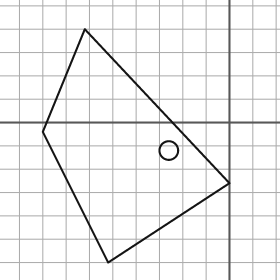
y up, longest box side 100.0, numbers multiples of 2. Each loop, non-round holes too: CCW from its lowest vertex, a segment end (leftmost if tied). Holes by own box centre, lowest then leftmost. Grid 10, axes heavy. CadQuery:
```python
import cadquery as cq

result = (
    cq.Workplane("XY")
    .moveTo(-52.0, -60.0)
    .lineTo(0.0, -26.0)
    .lineTo(-62.0, 40.0)
    .lineTo(-80.0, -4.0)
    .close()
    .moveTo(-26.0, -12.0)
    .circle(4.0)
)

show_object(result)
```